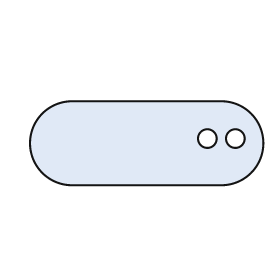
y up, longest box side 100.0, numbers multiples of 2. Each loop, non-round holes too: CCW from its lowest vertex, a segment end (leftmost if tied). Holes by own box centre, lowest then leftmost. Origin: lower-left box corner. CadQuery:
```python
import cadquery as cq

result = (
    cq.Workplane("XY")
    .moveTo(18.0, 0.0)
    .lineTo(82.0, 0.0)
    .threePointArc((100.0, 18.0), (82.0, 36.0))
    .lineTo(18.0, 36.0)
    .threePointArc((0.0, 18.0), (18.0, 0.0))
    .close()
    .moveTo(76.0, 20.0)
    .circle(4.0)
    .moveTo(88.0, 20.0)
    .circle(4.0)
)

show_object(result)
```